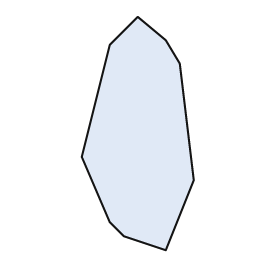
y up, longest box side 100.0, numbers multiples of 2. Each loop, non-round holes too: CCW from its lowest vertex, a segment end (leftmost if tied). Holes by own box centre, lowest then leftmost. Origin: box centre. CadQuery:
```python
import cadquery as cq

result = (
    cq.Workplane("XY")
    .moveTo(12.0, -50.0)
    .lineTo(24.0, -20.0)
    .lineTo(18.0, 30.0)
    .lineTo(12.0, 40.0)
    .lineTo(0.0, 50.0)
    .lineTo(-12.0, 38.0)
    .lineTo(-24.0, -10.0)
    .lineTo(-12.0, -38.0)
    .lineTo(-6.0, -44.0)
    .close()
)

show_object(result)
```